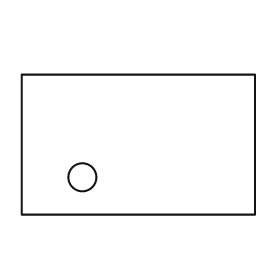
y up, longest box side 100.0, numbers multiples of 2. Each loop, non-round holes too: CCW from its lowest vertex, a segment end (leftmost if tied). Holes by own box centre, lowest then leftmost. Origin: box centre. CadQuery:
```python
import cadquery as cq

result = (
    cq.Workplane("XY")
    .moveTo(-50.0, -30.0)
    .lineTo(50.0, -30.0)
    .lineTo(50.0, 30.0)
    .lineTo(-50.0, 30.0)
    .close()
    .moveTo(-24.0, -14.0)
    .circle(6.0)
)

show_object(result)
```